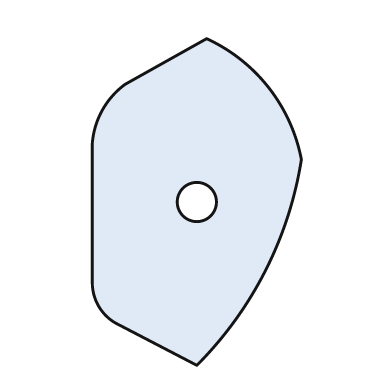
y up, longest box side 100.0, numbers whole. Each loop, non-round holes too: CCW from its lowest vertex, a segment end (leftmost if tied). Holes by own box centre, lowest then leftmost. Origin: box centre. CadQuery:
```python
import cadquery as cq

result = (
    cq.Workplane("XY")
    .moveTo(0.0, -50.0)
    .threePointArc((21.0, -21.0), (32.0, 13.0))
    .threePointArc((22.0, 35.0), (3.0, 50.0))
    .lineTo(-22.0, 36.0)
    .threePointArc((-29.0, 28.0), (-32.0, 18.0))
    .lineTo(-32.0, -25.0)
    .threePointArc((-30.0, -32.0), (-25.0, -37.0))
    .close()
    .moveTo(0.0, 0.0)
    .circle(6.0)
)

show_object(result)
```